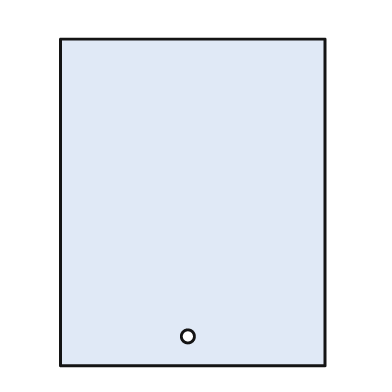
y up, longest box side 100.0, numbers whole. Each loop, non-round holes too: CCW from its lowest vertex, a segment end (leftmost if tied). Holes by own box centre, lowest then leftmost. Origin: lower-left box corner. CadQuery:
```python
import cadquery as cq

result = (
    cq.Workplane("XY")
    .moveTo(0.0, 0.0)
    .lineTo(81.0, 0.0)
    .lineTo(81.0, 100.0)
    .lineTo(0.0, 100.0)
    .close()
    .moveTo(39.0, 9.0)
    .circle(2.0)
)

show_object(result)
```